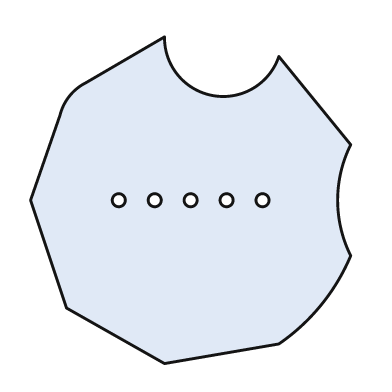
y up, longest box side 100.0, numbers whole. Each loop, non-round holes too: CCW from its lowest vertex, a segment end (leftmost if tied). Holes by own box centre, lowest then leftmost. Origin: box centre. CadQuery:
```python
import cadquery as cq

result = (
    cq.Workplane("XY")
    .moveTo(-8.0, -50.0)
    .lineTo(27.0, -44.0)
    .threePointArc((40.0, -32.0), (49.0, -17.0))
    .threePointArc((45.0, 0.0), (49.0, 17.0))
    .lineTo(27.0, 44.0)
    .threePointArc((7.0, 32.0), (-8.0, 50.0))
    .lineTo(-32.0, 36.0)
    .threePointArc((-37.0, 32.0), (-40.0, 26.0))
    .lineTo(-49.0, 0.0)
    .lineTo(-38.0, -33.0)
    .close()
    .moveTo(-22.0, 0.0)
    .circle(2.0)
    .moveTo(-11.0, 0.0)
    .circle(2.0)
    .moveTo(0.0, 0.0)
    .circle(2.0)
    .moveTo(11.0, 0.0)
    .circle(2.0)
    .moveTo(22.0, 0.0)
    .circle(2.0)
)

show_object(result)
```